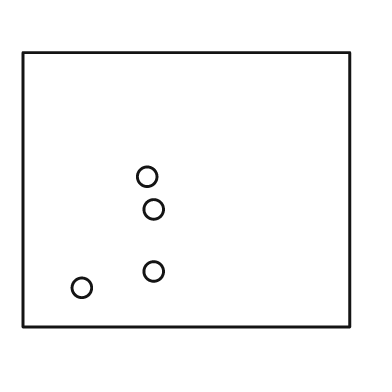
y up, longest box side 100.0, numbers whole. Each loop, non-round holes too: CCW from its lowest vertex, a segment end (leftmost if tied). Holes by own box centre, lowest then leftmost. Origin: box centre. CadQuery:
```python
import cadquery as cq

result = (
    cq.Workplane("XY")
    .moveTo(-50.0, -42.0)
    .lineTo(50.0, -42.0)
    .lineTo(50.0, 42.0)
    .lineTo(-50.0, 42.0)
    .close()
    .moveTo(-32.0, -30.0)
    .circle(3.0)
    .moveTo(-10.0, -25.0)
    .circle(3.0)
    .moveTo(-10.0, -6.0)
    .circle(3.0)
    .moveTo(-12.0, 4.0)
    .circle(3.0)
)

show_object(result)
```